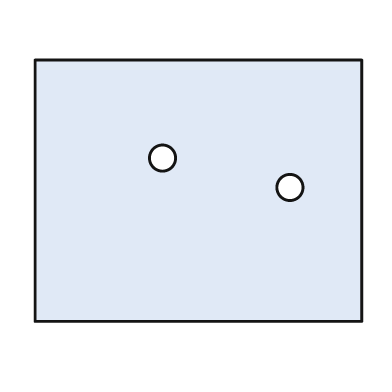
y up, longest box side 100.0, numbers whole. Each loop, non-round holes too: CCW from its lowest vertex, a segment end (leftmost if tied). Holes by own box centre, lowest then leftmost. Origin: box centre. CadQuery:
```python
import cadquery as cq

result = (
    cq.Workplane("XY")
    .moveTo(-50.0, -40.0)
    .lineTo(50.0, -40.0)
    .lineTo(50.0, 40.0)
    .lineTo(-50.0, 40.0)
    .close()
    .moveTo(28.0, 1.0)
    .circle(4.0)
    .moveTo(-11.0, 10.0)
    .circle(4.0)
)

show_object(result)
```